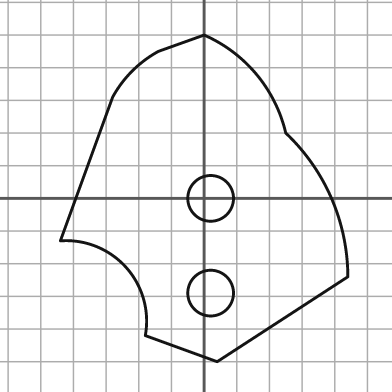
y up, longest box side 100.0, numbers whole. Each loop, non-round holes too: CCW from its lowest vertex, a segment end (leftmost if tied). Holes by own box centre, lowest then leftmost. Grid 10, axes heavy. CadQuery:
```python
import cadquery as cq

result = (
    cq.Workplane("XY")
    .moveTo(4.0, -50.0)
    .lineTo(44.0, -24.0)
    .threePointArc((39.0, 0.0), (25.0, 20.0))
    .threePointArc((16.0, 38.0), (0.0, 50.0))
    .lineTo(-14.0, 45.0)
    .threePointArc((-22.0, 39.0), (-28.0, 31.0))
    .lineTo(-44.0, -13.0)
    .threePointArc((-24.0, -21.0), (-18.0, -42.0))
    .close()
    .moveTo(2.0, -29.0)
    .circle(7.0)
    .moveTo(2.0, 0.0)
    .circle(7.0)
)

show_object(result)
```